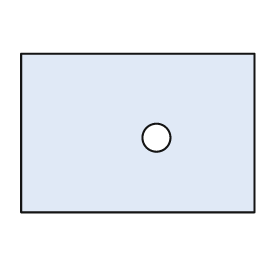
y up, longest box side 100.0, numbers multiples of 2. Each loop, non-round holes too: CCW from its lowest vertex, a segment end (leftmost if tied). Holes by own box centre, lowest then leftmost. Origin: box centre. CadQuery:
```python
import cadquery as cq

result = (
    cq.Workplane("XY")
    .moveTo(-50.0, -34.0)
    .lineTo(50.0, -34.0)
    .lineTo(50.0, 34.0)
    .lineTo(-50.0, 34.0)
    .close()
    .moveTo(8.0, -2.0)
    .circle(6.0)
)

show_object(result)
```